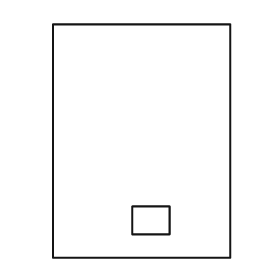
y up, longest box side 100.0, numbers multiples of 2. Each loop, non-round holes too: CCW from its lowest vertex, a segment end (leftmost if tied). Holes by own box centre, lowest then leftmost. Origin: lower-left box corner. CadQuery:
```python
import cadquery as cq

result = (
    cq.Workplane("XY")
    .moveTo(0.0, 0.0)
    .lineTo(76.0, 0.0)
    .lineTo(76.0, 100.0)
    .lineTo(0.0, 100.0)
    .close()
    .moveTo(34.0, 10.0)
    .lineTo(50.0, 10.0)
    .lineTo(50.0, 22.0)
    .lineTo(34.0, 22.0)
    .close()
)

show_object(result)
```